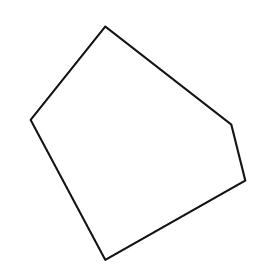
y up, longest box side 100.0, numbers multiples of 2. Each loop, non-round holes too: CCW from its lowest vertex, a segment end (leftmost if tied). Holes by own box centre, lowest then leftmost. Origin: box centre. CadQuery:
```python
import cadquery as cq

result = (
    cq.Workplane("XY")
    .moveTo(-14.0, -50.0)
    .lineTo(46.0, -16.0)
    .lineTo(40.0, 8.0)
    .lineTo(-14.0, 50.0)
    .lineTo(-46.0, 10.0)
    .close()
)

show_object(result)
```